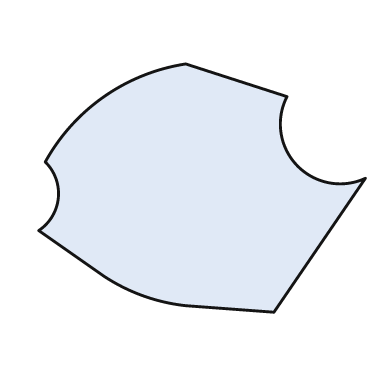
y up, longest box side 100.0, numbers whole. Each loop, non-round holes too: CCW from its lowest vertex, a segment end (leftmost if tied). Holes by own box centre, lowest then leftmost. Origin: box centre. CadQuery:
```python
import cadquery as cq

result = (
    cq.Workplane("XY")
    .moveTo(22.0, -38.0)
    .lineTo(50.0, 3.0)
    .threePointArc((29.0, 7.0), (26.0, 28.0))
    .lineTo(-5.0, 38.0)
    .threePointArc((-30.0, 28.0), (-48.0, 8.0))
    .threePointArc((-44.0, -3.0), (-50.0, -13.0))
    .lineTo(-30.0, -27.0)
    .threePointArc((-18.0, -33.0), (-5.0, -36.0))
    .close()
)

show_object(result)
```